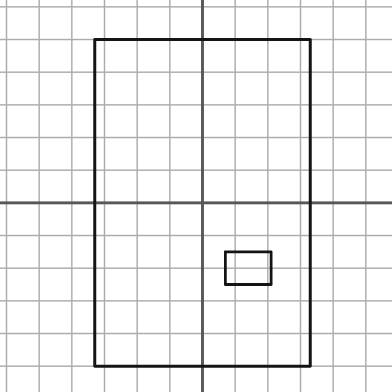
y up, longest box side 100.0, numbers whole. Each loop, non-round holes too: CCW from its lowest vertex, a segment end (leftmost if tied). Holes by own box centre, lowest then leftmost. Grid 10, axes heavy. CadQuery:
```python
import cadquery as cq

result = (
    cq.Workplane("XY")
    .moveTo(-33.0, -50.0)
    .lineTo(33.0, -50.0)
    .lineTo(33.0, 50.0)
    .lineTo(-33.0, 50.0)
    .close()
    .moveTo(7.0, -25.0)
    .lineTo(21.0, -25.0)
    .lineTo(21.0, -15.0)
    .lineTo(7.0, -15.0)
    .close()
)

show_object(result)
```